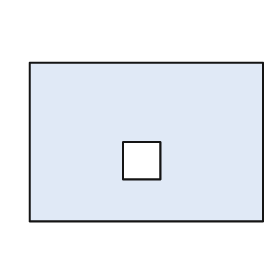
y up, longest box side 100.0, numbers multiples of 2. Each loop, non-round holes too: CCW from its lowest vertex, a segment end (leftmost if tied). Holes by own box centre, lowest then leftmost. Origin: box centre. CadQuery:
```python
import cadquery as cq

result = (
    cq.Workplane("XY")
    .moveTo(-50.0, -34.0)
    .lineTo(50.0, -34.0)
    .lineTo(50.0, 34.0)
    .lineTo(-50.0, 34.0)
    .close()
    .moveTo(-10.0, -16.0)
    .lineTo(6.0, -16.0)
    .lineTo(6.0, 0.0)
    .lineTo(-10.0, 0.0)
    .close()
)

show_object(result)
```